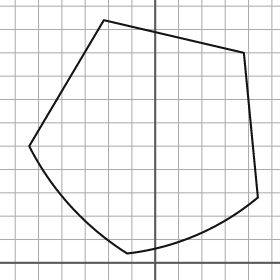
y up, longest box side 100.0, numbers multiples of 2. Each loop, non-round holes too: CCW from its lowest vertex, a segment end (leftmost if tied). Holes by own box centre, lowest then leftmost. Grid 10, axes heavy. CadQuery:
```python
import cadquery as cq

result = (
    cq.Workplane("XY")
    .moveTo(-12.0, 4.0)
    .threePointArc((18.0, 12.0), (44.0, 28.0))
    .lineTo(38.0, 90.0)
    .lineTo(-22.0, 104.0)
    .lineTo(-54.0, 50.0)
    .threePointArc((-36.0, 24.0), (-12.0, 4.0))
    .close()
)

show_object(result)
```